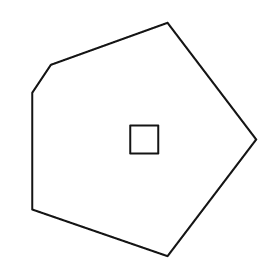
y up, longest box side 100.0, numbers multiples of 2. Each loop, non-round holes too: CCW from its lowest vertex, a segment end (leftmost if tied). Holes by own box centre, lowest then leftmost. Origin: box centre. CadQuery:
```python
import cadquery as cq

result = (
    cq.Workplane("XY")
    .moveTo(10.0, -50.0)
    .lineTo(48.0, 0.0)
    .lineTo(10.0, 50.0)
    .lineTo(-40.0, 32.0)
    .lineTo(-48.0, 20.0)
    .lineTo(-48.0, -30.0)
    .close()
    .moveTo(-6.0, -6.0)
    .lineTo(6.0, -6.0)
    .lineTo(6.0, 6.0)
    .lineTo(-6.0, 6.0)
    .close()
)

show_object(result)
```